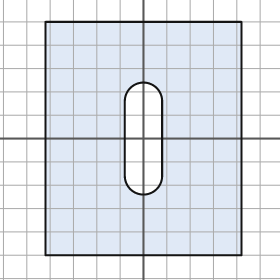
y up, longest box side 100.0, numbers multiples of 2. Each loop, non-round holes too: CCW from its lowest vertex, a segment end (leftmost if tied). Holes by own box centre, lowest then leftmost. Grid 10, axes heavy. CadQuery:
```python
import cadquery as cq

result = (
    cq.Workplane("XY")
    .moveTo(-42.0, -50.0)
    .lineTo(42.0, -50.0)
    .lineTo(42.0, 50.0)
    .lineTo(-42.0, 50.0)
    .close()
    .moveTo(-8.0, -16.0)
    .threePointArc((0.0, -24.0), (8.0, -16.0))
    .lineTo(8.0, 16.0)
    .threePointArc((0.0, 24.0), (-8.0, 16.0))
    .close()
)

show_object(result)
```